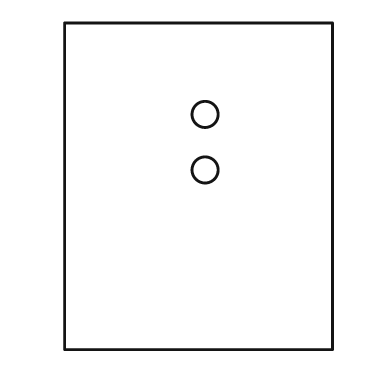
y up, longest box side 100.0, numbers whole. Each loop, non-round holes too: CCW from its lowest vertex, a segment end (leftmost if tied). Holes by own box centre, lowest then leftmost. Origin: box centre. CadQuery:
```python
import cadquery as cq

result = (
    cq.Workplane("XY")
    .moveTo(-41.0, -50.0)
    .lineTo(41.0, -50.0)
    .lineTo(41.0, 50.0)
    .lineTo(-41.0, 50.0)
    .close()
    .moveTo(2.0, 5.0)
    .circle(4.0)
    .moveTo(2.0, 22.0)
    .circle(4.0)
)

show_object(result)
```